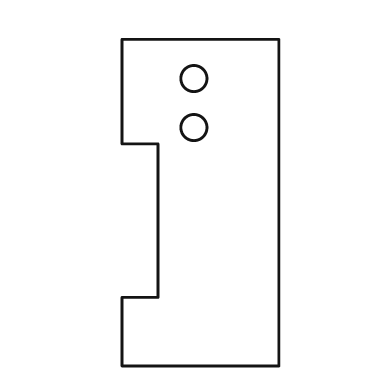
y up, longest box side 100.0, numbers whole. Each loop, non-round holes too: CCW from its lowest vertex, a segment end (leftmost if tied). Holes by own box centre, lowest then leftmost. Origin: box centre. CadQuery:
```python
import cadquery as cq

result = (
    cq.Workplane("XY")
    .moveTo(-24.0, -50.0)
    .lineTo(24.0, -50.0)
    .lineTo(24.0, 50.0)
    .lineTo(-24.0, 50.0)
    .lineTo(-24.0, 18.0)
    .lineTo(-13.0, 18.0)
    .lineTo(-13.0, -29.0)
    .lineTo(-24.0, -29.0)
    .close()
    .moveTo(-2.0, 23.0)
    .circle(4.0)
    .moveTo(-2.0, 38.0)
    .circle(4.0)
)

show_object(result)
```